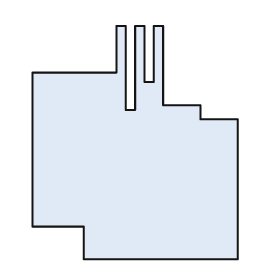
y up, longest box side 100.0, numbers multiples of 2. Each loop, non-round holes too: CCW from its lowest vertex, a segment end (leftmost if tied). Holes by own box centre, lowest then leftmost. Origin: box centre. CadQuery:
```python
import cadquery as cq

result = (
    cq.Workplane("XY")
    .moveTo(-22.0, -50.0)
    .lineTo(44.0, -50.0)
    .lineTo(44.0, 10.0)
    .lineTo(28.0, 10.0)
    .lineTo(28.0, 16.0)
    .lineTo(12.0, 16.0)
    .lineTo(12.0, 50.0)
    .lineTo(8.0, 50.0)
    .lineTo(8.0, 26.0)
    .lineTo(4.0, 26.0)
    .lineTo(4.0, 50.0)
    .lineTo(0.0, 50.0)
    .lineTo(0.0, 14.0)
    .lineTo(-4.0, 14.0)
    .lineTo(-4.0, 50.0)
    .lineTo(-8.0, 50.0)
    .lineTo(-8.0, 30.0)
    .lineTo(-44.0, 30.0)
    .lineTo(-44.0, -36.0)
    .lineTo(-22.0, -36.0)
    .close()
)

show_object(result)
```